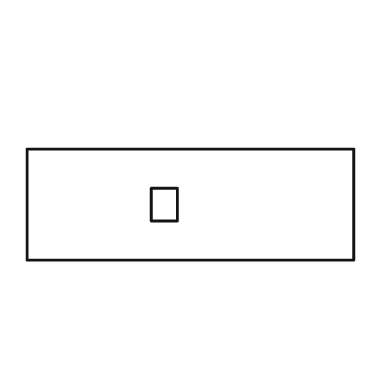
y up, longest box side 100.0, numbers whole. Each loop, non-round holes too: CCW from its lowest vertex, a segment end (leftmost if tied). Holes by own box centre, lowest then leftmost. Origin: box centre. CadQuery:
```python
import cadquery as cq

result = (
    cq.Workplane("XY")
    .moveTo(-50.0, -17.0)
    .lineTo(50.0, -17.0)
    .lineTo(50.0, 17.0)
    .lineTo(-50.0, 17.0)
    .close()
    .moveTo(-12.0, -5.0)
    .lineTo(-4.0, -5.0)
    .lineTo(-4.0, 5.0)
    .lineTo(-12.0, 5.0)
    .close()
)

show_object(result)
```